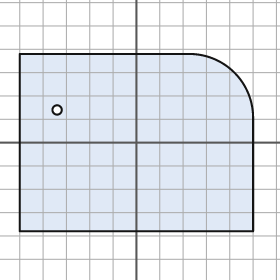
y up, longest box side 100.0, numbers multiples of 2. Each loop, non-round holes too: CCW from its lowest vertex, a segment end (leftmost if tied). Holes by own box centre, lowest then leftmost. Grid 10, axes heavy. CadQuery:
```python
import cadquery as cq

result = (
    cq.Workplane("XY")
    .moveTo(-50.0, -38.0)
    .lineTo(50.0, -38.0)
    .lineTo(50.0, 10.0)
    .threePointArc((42.0, 30.0), (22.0, 38.0))
    .lineTo(-50.0, 38.0)
    .close()
    .moveTo(-34.0, 14.0)
    .circle(2.0)
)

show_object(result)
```